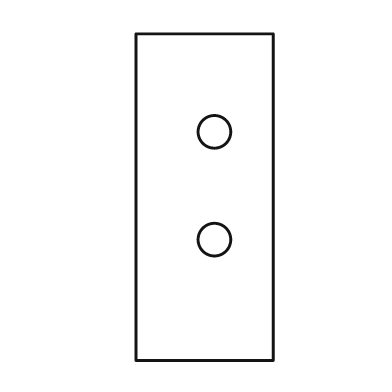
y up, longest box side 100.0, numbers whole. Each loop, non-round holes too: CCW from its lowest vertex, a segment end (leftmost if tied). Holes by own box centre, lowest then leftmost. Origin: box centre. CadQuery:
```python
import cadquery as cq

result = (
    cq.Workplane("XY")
    .moveTo(-21.0, -50.0)
    .lineTo(21.0, -50.0)
    .lineTo(21.0, 50.0)
    .lineTo(-21.0, 50.0)
    .close()
    .moveTo(3.0, -13.0)
    .circle(5.0)
    .moveTo(3.0, 20.0)
    .circle(5.0)
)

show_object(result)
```